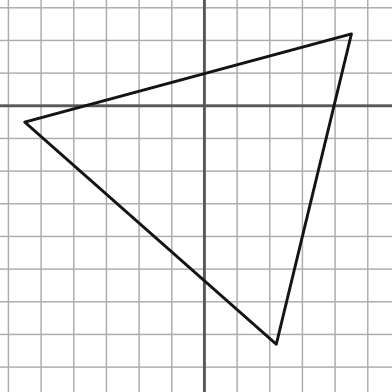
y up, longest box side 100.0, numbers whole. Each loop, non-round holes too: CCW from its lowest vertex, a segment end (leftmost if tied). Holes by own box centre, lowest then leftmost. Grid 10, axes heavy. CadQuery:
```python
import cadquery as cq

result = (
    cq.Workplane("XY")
    .moveTo(22.0, -73.0)
    .lineTo(45.0, 22.0)
    .lineTo(-55.0, -5.0)
    .close()
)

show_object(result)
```